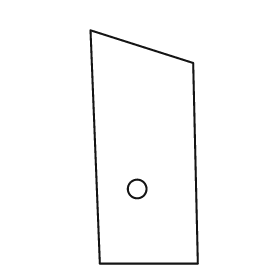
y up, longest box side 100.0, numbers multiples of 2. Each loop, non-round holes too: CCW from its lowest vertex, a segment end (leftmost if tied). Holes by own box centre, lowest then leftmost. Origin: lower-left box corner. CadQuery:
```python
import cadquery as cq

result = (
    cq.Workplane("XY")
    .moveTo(4.0, 0.0)
    .lineTo(46.0, 0.0)
    .lineTo(44.0, 86.0)
    .lineTo(0.0, 100.0)
    .close()
    .moveTo(20.0, 32.0)
    .circle(4.0)
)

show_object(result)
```